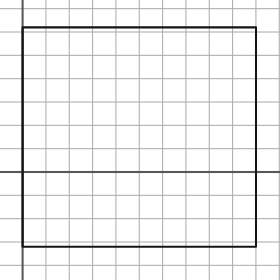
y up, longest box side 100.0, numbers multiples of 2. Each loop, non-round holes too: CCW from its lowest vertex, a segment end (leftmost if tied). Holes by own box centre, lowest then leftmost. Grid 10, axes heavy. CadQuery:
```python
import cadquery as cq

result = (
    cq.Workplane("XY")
    .moveTo(0.0, -32.0)
    .lineTo(100.0, -32.0)
    .lineTo(100.0, 62.0)
    .lineTo(0.0, 62.0)
    .close()
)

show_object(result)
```